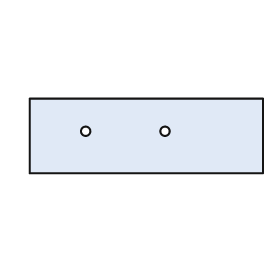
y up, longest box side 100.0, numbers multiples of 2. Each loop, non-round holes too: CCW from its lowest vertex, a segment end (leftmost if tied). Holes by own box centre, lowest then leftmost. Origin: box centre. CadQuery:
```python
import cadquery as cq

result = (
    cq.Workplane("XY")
    .moveTo(-50.0, -16.0)
    .lineTo(50.0, -16.0)
    .lineTo(50.0, 16.0)
    .lineTo(-50.0, 16.0)
    .close()
    .moveTo(-26.0, 2.0)
    .circle(2.0)
    .moveTo(8.0, 2.0)
    .circle(2.0)
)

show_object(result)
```